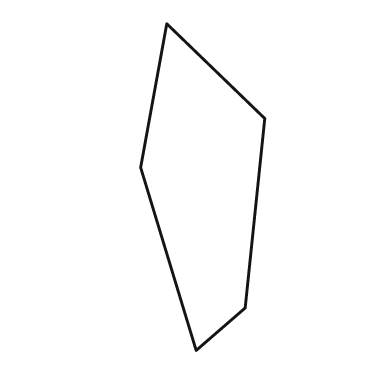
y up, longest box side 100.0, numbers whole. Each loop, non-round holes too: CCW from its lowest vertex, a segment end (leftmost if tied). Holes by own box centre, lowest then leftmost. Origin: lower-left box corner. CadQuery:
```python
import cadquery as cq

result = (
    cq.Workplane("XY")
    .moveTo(17.0, 0.0)
    .lineTo(32.0, 13.0)
    .lineTo(38.0, 71.0)
    .lineTo(8.0, 100.0)
    .lineTo(0.0, 56.0)
    .close()
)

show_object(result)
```